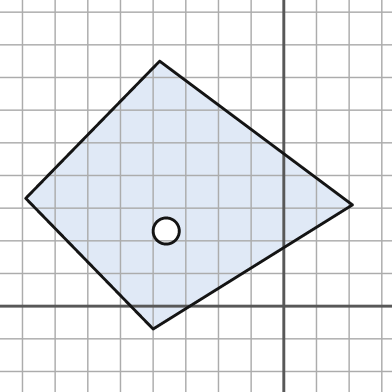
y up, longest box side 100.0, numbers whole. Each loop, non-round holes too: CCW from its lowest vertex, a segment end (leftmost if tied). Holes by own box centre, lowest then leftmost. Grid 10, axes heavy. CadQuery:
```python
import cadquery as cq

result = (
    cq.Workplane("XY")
    .moveTo(-40.0, -7.0)
    .lineTo(21.0, 31.0)
    .lineTo(-38.0, 75.0)
    .lineTo(-79.0, 33.0)
    .close()
    .moveTo(-36.0, 23.0)
    .circle(4.0)
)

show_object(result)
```